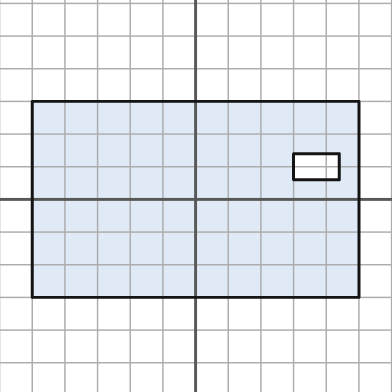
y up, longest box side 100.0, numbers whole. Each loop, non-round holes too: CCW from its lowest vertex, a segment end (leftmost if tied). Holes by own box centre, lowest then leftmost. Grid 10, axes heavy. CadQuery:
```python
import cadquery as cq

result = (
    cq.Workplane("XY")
    .moveTo(-50.0, -30.0)
    .lineTo(50.0, -30.0)
    .lineTo(50.0, 30.0)
    .lineTo(-50.0, 30.0)
    .close()
    .moveTo(30.0, 6.0)
    .lineTo(44.0, 6.0)
    .lineTo(44.0, 14.0)
    .lineTo(30.0, 14.0)
    .close()
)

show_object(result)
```